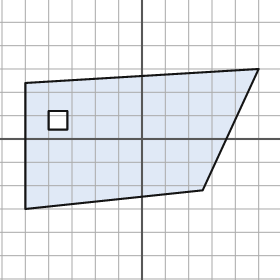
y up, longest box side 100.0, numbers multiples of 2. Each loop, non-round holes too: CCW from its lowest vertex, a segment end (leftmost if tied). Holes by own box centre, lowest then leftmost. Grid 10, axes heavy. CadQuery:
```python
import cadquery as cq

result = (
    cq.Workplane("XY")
    .moveTo(-50.0, -30.0)
    .lineTo(26.0, -22.0)
    .lineTo(50.0, 30.0)
    .lineTo(-50.0, 24.0)
    .close()
    .moveTo(-40.0, 4.0)
    .lineTo(-32.0, 4.0)
    .lineTo(-32.0, 12.0)
    .lineTo(-40.0, 12.0)
    .close()
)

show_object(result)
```